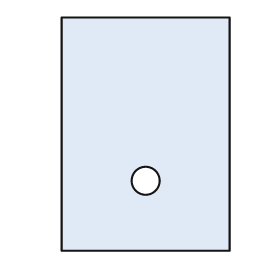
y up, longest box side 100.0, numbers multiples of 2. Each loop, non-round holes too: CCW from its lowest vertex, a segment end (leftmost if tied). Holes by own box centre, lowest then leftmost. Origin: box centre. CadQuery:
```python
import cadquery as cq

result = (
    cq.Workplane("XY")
    .moveTo(-36.0, -50.0)
    .lineTo(36.0, -50.0)
    .lineTo(36.0, 50.0)
    .lineTo(-36.0, 50.0)
    .close()
    .moveTo(0.0, -20.0)
    .circle(6.0)
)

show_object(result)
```